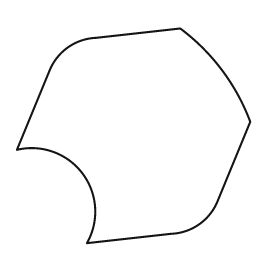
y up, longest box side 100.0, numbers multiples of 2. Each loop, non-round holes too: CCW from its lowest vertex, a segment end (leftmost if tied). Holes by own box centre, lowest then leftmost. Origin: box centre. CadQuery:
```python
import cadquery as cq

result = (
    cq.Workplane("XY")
    .moveTo(-20.0, -46.0)
    .lineTo(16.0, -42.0)
    .threePointArc((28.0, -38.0), (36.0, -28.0))
    .lineTo(50.0, 6.0)
    .threePointArc((38.0, 28.0), (20.0, 46.0))
    .lineTo(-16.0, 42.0)
    .threePointArc((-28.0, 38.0), (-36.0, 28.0))
    .lineTo(-50.0, -6.0)
    .threePointArc((-22.0, -16.0), (-20.0, -46.0))
    .close()
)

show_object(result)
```